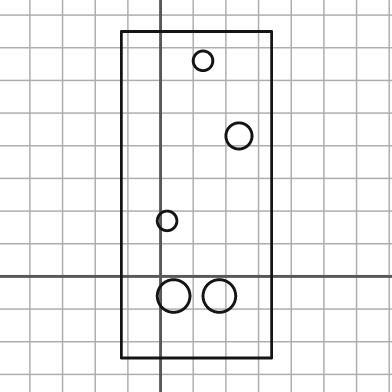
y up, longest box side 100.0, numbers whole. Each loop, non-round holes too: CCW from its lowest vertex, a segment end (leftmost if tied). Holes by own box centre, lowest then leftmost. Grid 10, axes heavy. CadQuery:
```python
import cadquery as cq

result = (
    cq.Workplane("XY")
    .moveTo(-12.0, -25.0)
    .lineTo(34.0, -25.0)
    .lineTo(34.0, 75.0)
    .lineTo(-12.0, 75.0)
    .close()
    .moveTo(4.0, -6.0)
    .circle(5.0)
    .moveTo(18.0, -6.0)
    .circle(5.0)
    .moveTo(2.0, 17.0)
    .circle(3.0)
    .moveTo(24.0, 43.0)
    .circle(4.0)
    .moveTo(13.0, 66.0)
    .circle(3.0)
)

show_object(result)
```